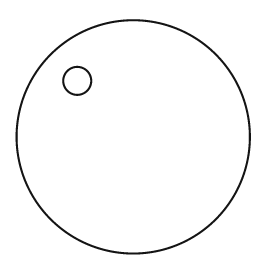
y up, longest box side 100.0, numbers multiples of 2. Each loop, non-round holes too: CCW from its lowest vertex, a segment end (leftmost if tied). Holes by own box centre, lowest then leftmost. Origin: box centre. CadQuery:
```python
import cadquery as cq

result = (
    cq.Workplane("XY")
    .moveTo(0.0, 0.0)
    .circle(50.0)
    .moveTo(-24.0, 24.0)
    .circle(6.0)
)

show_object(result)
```